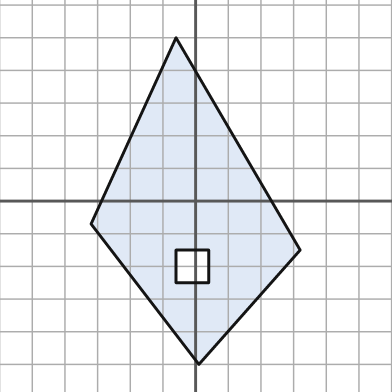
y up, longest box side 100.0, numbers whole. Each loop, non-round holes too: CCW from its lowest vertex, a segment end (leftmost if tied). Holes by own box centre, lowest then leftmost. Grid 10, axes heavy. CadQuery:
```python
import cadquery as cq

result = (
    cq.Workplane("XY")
    .moveTo(1.0, -50.0)
    .lineTo(32.0, -15.0)
    .lineTo(-6.0, 50.0)
    .lineTo(-32.0, -7.0)
    .close()
    .moveTo(-6.0, -25.0)
    .lineTo(4.0, -25.0)
    .lineTo(4.0, -15.0)
    .lineTo(-6.0, -15.0)
    .close()
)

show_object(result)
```